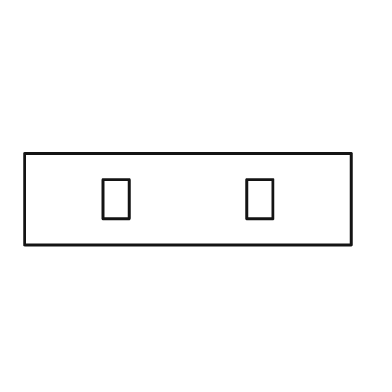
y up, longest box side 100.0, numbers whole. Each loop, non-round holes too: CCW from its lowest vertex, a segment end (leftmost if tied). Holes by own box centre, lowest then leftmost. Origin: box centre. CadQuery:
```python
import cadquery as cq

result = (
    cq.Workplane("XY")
    .moveTo(-50.0, -14.0)
    .lineTo(50.0, -14.0)
    .lineTo(50.0, 14.0)
    .lineTo(-50.0, 14.0)
    .close()
    .moveTo(-26.0, -6.0)
    .lineTo(-18.0, -6.0)
    .lineTo(-18.0, 6.0)
    .lineTo(-26.0, 6.0)
    .close()
    .moveTo(18.0, -6.0)
    .lineTo(26.0, -6.0)
    .lineTo(26.0, 6.0)
    .lineTo(18.0, 6.0)
    .close()
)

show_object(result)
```